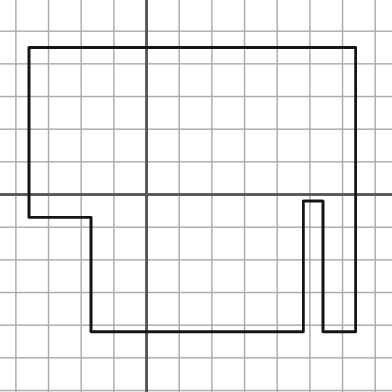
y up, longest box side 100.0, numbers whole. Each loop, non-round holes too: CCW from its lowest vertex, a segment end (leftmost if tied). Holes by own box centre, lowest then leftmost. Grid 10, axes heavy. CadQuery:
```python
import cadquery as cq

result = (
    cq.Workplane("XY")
    .moveTo(-17.0, -42.0)
    .lineTo(48.0, -42.0)
    .lineTo(48.0, -2.0)
    .lineTo(54.0, -2.0)
    .lineTo(54.0, -42.0)
    .lineTo(64.0, -42.0)
    .lineTo(64.0, 45.0)
    .lineTo(-36.0, 45.0)
    .lineTo(-36.0, -7.0)
    .lineTo(-17.0, -7.0)
    .close()
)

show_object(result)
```